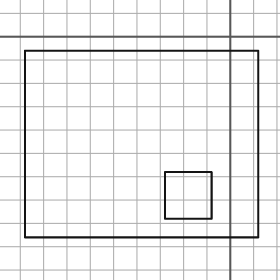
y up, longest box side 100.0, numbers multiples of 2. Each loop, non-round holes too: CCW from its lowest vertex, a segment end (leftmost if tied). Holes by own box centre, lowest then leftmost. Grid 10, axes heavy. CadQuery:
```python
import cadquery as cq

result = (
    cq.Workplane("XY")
    .moveTo(-88.0, -86.0)
    .lineTo(12.0, -86.0)
    .lineTo(12.0, -6.0)
    .lineTo(-88.0, -6.0)
    .close()
    .moveTo(-28.0, -78.0)
    .lineTo(-8.0, -78.0)
    .lineTo(-8.0, -58.0)
    .lineTo(-28.0, -58.0)
    .close()
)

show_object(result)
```